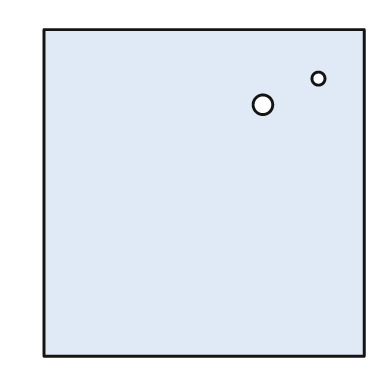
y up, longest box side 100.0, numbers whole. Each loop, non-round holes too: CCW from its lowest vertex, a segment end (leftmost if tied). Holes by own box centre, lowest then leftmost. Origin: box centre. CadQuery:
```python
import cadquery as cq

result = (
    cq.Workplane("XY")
    .moveTo(-49.0, -50.0)
    .lineTo(49.0, -50.0)
    .lineTo(49.0, 50.0)
    .lineTo(-49.0, 50.0)
    .close()
    .moveTo(18.0, 27.0)
    .circle(3.0)
    .moveTo(35.0, 35.0)
    .circle(2.0)
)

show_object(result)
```